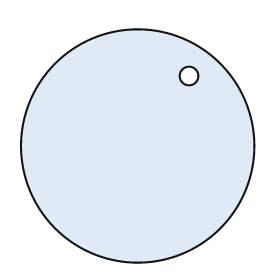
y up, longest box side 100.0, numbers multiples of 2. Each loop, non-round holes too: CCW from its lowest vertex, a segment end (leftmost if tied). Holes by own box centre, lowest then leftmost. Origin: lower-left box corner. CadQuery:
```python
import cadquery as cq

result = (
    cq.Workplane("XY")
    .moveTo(50.0, 50.0)
    .circle(50.0)
    .moveTo(72.0, 80.0)
    .circle(4.0)
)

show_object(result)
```